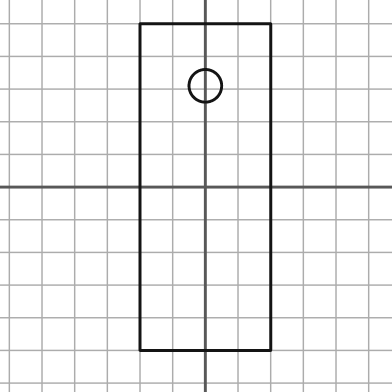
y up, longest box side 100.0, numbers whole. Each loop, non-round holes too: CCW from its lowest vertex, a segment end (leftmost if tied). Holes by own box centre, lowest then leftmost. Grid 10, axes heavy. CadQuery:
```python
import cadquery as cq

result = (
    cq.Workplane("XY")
    .moveTo(-20.0, -50.0)
    .lineTo(20.0, -50.0)
    .lineTo(20.0, 50.0)
    .lineTo(-20.0, 50.0)
    .close()
    .moveTo(0.0, 31.0)
    .circle(5.0)
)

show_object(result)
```